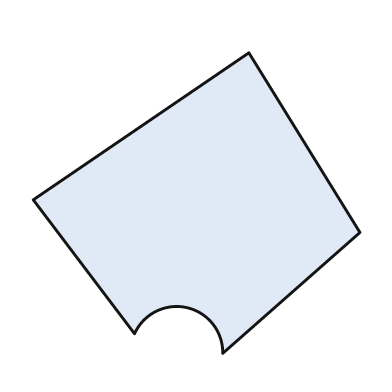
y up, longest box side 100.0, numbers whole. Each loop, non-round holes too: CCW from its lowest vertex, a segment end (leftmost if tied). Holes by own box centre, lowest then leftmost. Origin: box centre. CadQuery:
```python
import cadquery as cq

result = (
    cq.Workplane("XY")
    .moveTo(8.0, -46.0)
    .lineTo(50.0, -9.0)
    .lineTo(16.0, 46.0)
    .lineTo(-50.0, 1.0)
    .lineTo(-19.0, -40.0)
    .threePointArc((-3.0, -32.0), (8.0, -46.0))
    .close()
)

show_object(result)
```